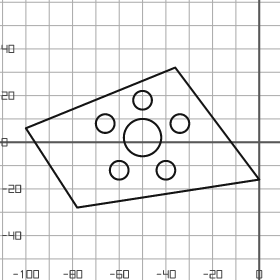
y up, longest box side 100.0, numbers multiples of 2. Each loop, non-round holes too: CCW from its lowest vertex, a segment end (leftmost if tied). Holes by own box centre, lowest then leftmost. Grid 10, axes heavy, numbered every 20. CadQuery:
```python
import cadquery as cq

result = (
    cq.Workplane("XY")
    .moveTo(-78.0, -28.0)
    .lineTo(0.0, -16.0)
    .lineTo(-36.0, 32.0)
    .lineTo(-100.0, 6.0)
    .close()
    .moveTo(-60.0, -12.0)
    .circle(4.0)
    .moveTo(-40.0, -12.0)
    .circle(4.0)
    .moveTo(-50.0, 2.0)
    .circle(8.0)
    .moveTo(-66.0, 8.0)
    .circle(4.0)
    .moveTo(-34.0, 8.0)
    .circle(4.0)
    .moveTo(-50.0, 18.0)
    .circle(4.0)
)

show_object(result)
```